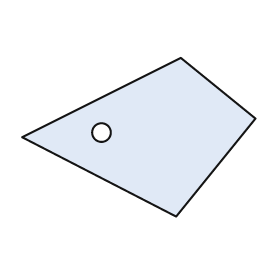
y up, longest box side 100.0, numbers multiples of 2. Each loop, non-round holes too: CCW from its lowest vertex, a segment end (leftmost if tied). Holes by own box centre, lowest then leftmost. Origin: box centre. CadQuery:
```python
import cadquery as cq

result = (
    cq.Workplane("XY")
    .moveTo(16.0, -34.0)
    .lineTo(50.0, 8.0)
    .lineTo(18.0, 34.0)
    .lineTo(-50.0, 0.0)
    .close()
    .moveTo(-16.0, 2.0)
    .circle(4.0)
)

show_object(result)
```